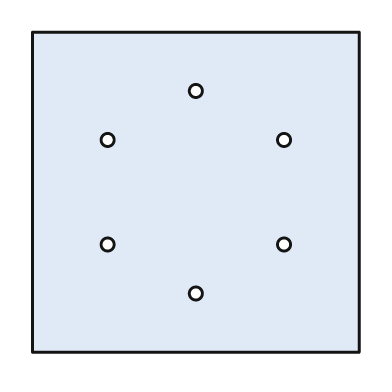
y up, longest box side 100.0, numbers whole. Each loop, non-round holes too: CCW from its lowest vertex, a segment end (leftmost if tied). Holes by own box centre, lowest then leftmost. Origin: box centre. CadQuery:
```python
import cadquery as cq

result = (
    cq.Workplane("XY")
    .moveTo(-50.0, -49.0)
    .lineTo(50.0, -49.0)
    .lineTo(50.0, 49.0)
    .lineTo(-50.0, 49.0)
    .close()
    .moveTo(0.0, -31.0)
    .circle(2.0)
    .moveTo(-27.0, -16.0)
    .circle(2.0)
    .moveTo(27.0, -16.0)
    .circle(2.0)
    .moveTo(-27.0, 16.0)
    .circle(2.0)
    .moveTo(27.0, 16.0)
    .circle(2.0)
    .moveTo(0.0, 31.0)
    .circle(2.0)
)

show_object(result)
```